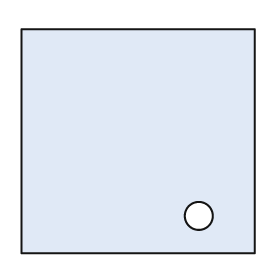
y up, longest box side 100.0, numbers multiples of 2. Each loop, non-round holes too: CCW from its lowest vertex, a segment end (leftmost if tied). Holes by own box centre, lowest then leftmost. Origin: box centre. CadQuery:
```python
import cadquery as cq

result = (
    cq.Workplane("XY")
    .moveTo(-50.0, -48.0)
    .lineTo(50.0, -48.0)
    .lineTo(50.0, 48.0)
    .lineTo(-50.0, 48.0)
    .close()
    .moveTo(26.0, -32.0)
    .circle(6.0)
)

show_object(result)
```